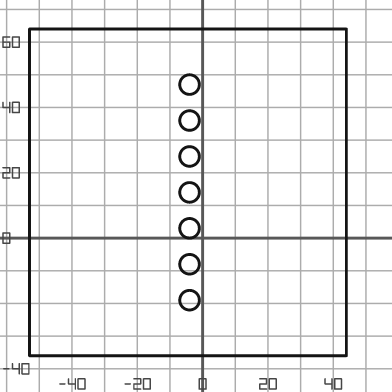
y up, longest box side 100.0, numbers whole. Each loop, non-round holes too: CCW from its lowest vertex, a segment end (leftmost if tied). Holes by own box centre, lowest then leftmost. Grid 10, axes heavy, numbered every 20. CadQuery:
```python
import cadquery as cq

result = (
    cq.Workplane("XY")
    .moveTo(-53.0, -36.0)
    .lineTo(44.0, -36.0)
    .lineTo(44.0, 64.0)
    .lineTo(-53.0, 64.0)
    .close()
    .moveTo(-4.0, -19.0)
    .circle(3.0)
    .moveTo(-4.0, -8.0)
    .circle(3.0)
    .moveTo(-4.0, 3.0)
    .circle(3.0)
    .moveTo(-4.0, 14.0)
    .circle(3.0)
    .moveTo(-4.0, 25.0)
    .circle(3.0)
    .moveTo(-4.0, 36.0)
    .circle(3.0)
    .moveTo(-4.0, 47.0)
    .circle(3.0)
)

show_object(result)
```